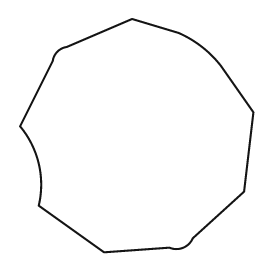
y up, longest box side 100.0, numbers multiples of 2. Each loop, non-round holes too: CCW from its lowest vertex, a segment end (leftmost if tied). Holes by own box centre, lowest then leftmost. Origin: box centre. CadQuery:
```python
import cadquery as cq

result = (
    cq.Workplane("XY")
    .moveTo(-14.0, -50.0)
    .lineTo(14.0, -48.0)
    .threePointArc((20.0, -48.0), (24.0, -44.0))
    .lineTo(46.0, -24.0)
    .lineTo(50.0, 10.0)
    .lineTo(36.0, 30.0)
    .threePointArc((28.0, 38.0), (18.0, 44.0))
    .lineTo(-2.0, 50.0)
    .lineTo(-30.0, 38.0)
    .threePointArc((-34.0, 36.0), (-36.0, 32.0))
    .lineTo(-50.0, 4.0)
    .threePointArc((-42.0, -12.0), (-42.0, -30.0))
    .close()
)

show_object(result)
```